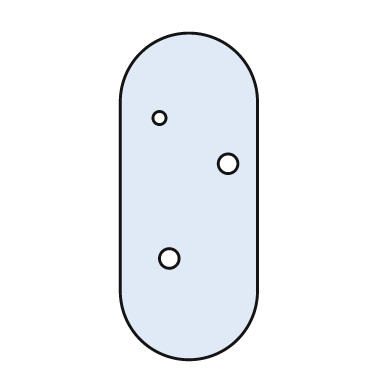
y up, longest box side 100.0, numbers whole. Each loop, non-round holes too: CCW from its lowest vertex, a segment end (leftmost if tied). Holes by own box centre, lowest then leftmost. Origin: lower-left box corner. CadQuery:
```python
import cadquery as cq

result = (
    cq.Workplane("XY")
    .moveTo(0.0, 21.0)
    .threePointArc((21.0, 0.0), (42.0, 21.0))
    .lineTo(42.0, 79.0)
    .threePointArc((21.0, 100.0), (0.0, 79.0))
    .close()
    .moveTo(15.0, 31.0)
    .circle(3.0)
    .moveTo(33.0, 60.0)
    .circle(3.0)
    .moveTo(12.0, 74.0)
    .circle(2.0)
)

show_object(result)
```